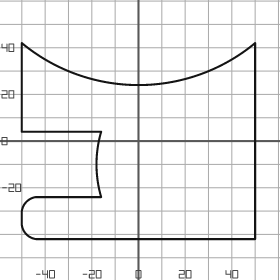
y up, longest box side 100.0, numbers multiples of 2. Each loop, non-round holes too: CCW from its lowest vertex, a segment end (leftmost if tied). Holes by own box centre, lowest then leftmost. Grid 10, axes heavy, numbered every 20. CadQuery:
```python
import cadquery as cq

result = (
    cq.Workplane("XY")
    .moveTo(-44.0, -42.0)
    .lineTo(50.0, -42.0)
    .lineTo(50.0, 42.0)
    .threePointArc((0.0, 24.0), (-50.0, 42.0))
    .lineTo(-50.0, 4.0)
    .lineTo(-16.0, 4.0)
    .threePointArc((-18.0, -10.0), (-16.0, -24.0))
    .lineTo(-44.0, -24.0)
    .threePointArc((-48.0, -26.0), (-50.0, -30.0))
    .lineTo(-50.0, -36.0)
    .threePointArc((-48.0, -40.0), (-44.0, -42.0))
    .close()
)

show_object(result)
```